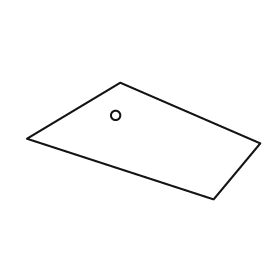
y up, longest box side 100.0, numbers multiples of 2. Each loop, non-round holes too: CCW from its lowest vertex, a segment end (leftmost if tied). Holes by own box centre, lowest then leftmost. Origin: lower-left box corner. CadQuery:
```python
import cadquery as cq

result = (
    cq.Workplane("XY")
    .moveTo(80.0, 0.0)
    .lineTo(100.0, 24.0)
    .lineTo(40.0, 50.0)
    .lineTo(0.0, 26.0)
    .close()
    .moveTo(38.0, 36.0)
    .circle(2.0)
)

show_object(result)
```